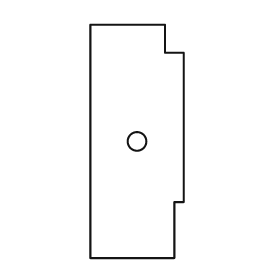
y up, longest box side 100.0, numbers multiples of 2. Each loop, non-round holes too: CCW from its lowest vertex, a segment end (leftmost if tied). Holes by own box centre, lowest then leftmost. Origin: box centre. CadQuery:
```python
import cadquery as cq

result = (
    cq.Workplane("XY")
    .moveTo(-20.0, -50.0)
    .lineTo(16.0, -50.0)
    .lineTo(16.0, -26.0)
    .lineTo(20.0, -26.0)
    .lineTo(20.0, 38.0)
    .lineTo(12.0, 38.0)
    .lineTo(12.0, 50.0)
    .lineTo(-20.0, 50.0)
    .close()
    .moveTo(0.0, 0.0)
    .circle(4.0)
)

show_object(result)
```